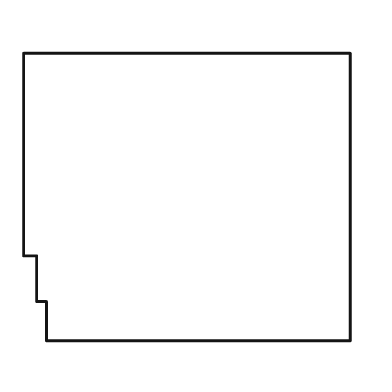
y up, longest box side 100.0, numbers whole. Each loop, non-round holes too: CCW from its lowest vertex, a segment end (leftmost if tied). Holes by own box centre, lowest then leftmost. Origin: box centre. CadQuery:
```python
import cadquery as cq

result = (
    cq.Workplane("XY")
    .moveTo(-43.0, -44.0)
    .lineTo(50.0, -44.0)
    .lineTo(50.0, 44.0)
    .lineTo(-50.0, 44.0)
    .lineTo(-50.0, -18.0)
    .lineTo(-46.0, -18.0)
    .lineTo(-46.0, -32.0)
    .lineTo(-43.0, -32.0)
    .close()
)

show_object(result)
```